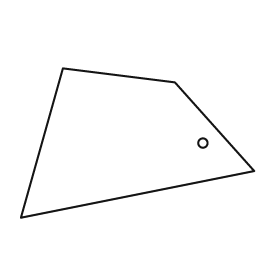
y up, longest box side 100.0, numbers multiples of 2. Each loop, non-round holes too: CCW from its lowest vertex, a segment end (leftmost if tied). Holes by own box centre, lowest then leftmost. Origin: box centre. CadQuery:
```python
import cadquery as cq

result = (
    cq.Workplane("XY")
    .moveTo(-50.0, -32.0)
    .lineTo(50.0, -12.0)
    .lineTo(16.0, 26.0)
    .lineTo(-32.0, 32.0)
    .close()
    .moveTo(28.0, 0.0)
    .circle(2.0)
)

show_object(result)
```